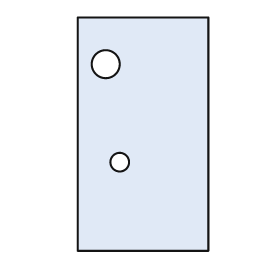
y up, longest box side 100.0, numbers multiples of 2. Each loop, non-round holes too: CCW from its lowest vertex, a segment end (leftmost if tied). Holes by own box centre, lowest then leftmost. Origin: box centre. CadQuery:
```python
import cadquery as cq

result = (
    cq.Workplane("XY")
    .moveTo(-28.0, -50.0)
    .lineTo(28.0, -50.0)
    .lineTo(28.0, 50.0)
    .lineTo(-28.0, 50.0)
    .close()
    .moveTo(-10.0, -12.0)
    .circle(4.0)
    .moveTo(-16.0, 30.0)
    .circle(6.0)
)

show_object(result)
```